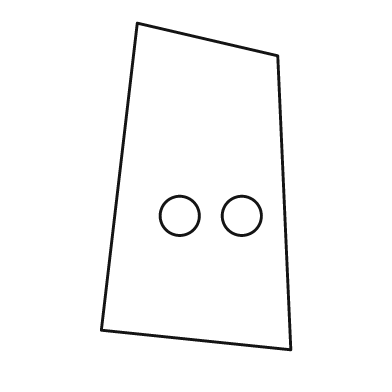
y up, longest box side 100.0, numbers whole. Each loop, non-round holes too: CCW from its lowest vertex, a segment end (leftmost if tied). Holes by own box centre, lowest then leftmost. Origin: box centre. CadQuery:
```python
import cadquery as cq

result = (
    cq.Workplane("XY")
    .moveTo(29.0, -50.0)
    .lineTo(25.0, 40.0)
    .lineTo(-18.0, 50.0)
    .lineTo(-29.0, -44.0)
    .close()
    .moveTo(-5.0, -9.0)
    .circle(6.0)
    .moveTo(14.0, -9.0)
    .circle(6.0)
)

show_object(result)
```